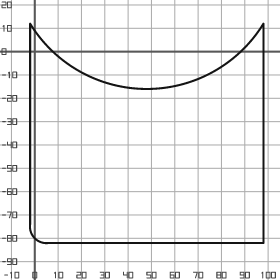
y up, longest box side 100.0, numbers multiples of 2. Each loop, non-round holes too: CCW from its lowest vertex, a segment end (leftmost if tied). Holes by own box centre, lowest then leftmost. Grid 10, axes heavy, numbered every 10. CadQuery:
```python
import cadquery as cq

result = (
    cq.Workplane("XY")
    .moveTo(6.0, -82.0)
    .lineTo(98.0, -82.0)
    .lineTo(98.0, 12.0)
    .threePointArc((48.0, -16.0), (-2.0, 12.0))
    .lineTo(-2.0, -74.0)
    .threePointArc((0.0, -80.0), (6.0, -82.0))
    .close()
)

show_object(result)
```